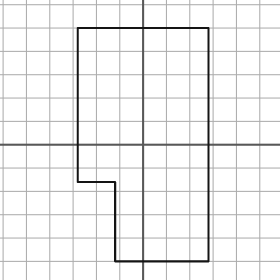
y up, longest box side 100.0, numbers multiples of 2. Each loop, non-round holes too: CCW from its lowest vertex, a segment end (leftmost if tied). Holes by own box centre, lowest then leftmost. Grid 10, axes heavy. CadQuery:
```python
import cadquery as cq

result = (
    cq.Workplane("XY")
    .moveTo(-12.0, -50.0)
    .lineTo(28.0, -50.0)
    .lineTo(28.0, 50.0)
    .lineTo(-28.0, 50.0)
    .lineTo(-28.0, -16.0)
    .lineTo(-12.0, -16.0)
    .close()
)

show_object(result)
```